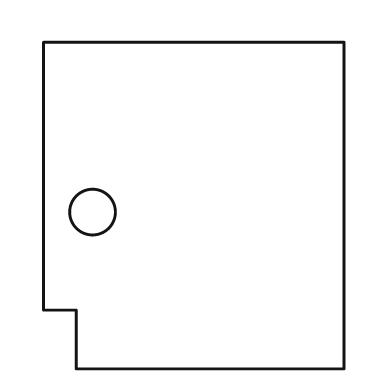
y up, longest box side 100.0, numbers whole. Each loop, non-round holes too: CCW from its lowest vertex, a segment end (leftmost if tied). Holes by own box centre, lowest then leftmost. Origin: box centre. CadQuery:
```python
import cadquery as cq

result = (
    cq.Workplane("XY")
    .moveTo(-36.0, -50.0)
    .lineTo(46.0, -50.0)
    .lineTo(46.0, 50.0)
    .lineTo(-46.0, 50.0)
    .lineTo(-46.0, -32.0)
    .lineTo(-36.0, -32.0)
    .close()
    .moveTo(-31.0, -2.0)
    .circle(7.0)
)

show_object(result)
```